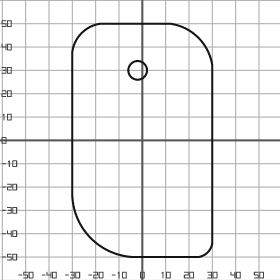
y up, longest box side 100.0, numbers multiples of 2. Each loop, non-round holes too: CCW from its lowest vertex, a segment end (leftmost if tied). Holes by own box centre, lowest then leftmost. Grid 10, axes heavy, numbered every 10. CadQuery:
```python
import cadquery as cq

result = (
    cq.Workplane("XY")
    .moveTo(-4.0, -50.0)
    .lineTo(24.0, -50.0)
    .threePointArc((28.0, -48.0), (30.0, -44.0))
    .lineTo(30.0, 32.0)
    .threePointArc((24.0, 44.0), (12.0, 50.0))
    .lineTo(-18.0, 50.0)
    .threePointArc((-26.0, 46.0), (-30.0, 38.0))
    .lineTo(-30.0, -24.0)
    .threePointArc((-22.0, -42.0), (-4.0, -50.0))
    .close()
    .moveTo(-2.0, 30.0)
    .circle(4.0)
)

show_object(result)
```